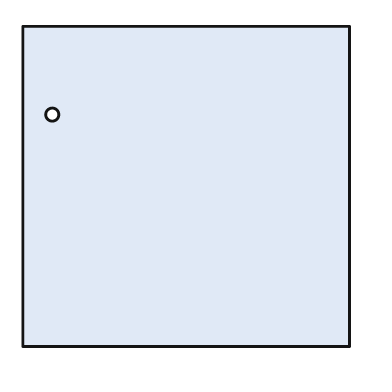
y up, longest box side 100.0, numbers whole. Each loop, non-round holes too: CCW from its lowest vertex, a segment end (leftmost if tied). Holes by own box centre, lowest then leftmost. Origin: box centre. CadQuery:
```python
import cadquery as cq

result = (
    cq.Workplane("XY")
    .moveTo(-50.0, -49.0)
    .lineTo(50.0, -49.0)
    .lineTo(50.0, 49.0)
    .lineTo(-50.0, 49.0)
    .close()
    .moveTo(-41.0, 22.0)
    .circle(2.0)
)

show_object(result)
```